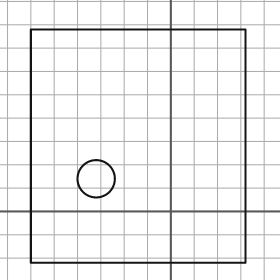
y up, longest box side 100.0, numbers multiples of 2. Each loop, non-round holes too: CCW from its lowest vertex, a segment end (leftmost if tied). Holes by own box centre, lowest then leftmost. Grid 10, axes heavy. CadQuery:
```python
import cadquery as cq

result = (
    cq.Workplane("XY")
    .moveTo(-60.0, -22.0)
    .lineTo(32.0, -22.0)
    .lineTo(32.0, 78.0)
    .lineTo(-60.0, 78.0)
    .close()
    .moveTo(-32.0, 14.0)
    .circle(8.0)
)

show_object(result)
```